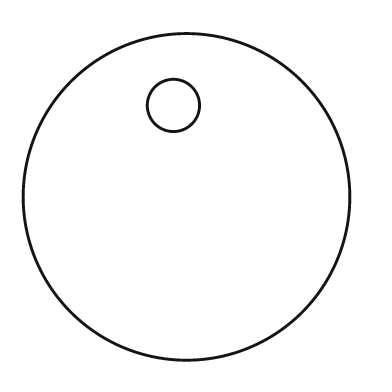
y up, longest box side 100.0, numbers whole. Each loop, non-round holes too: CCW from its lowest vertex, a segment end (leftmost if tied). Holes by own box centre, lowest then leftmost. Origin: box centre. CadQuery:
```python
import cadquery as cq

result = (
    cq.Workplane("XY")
    .moveTo(0.0, 0.0)
    .circle(50.0)
    .moveTo(-4.0, 28.0)
    .circle(8.0)
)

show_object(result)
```